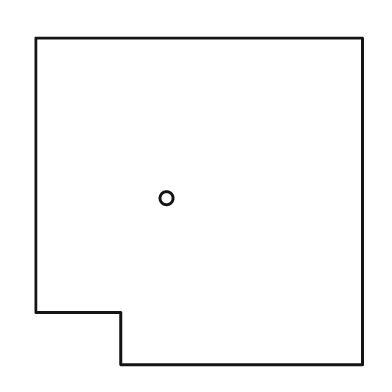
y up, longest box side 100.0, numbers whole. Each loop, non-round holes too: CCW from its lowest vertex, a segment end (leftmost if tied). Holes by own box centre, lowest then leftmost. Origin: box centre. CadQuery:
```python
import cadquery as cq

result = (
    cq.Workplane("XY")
    .moveTo(-24.0, -50.0)
    .lineTo(50.0, -50.0)
    .lineTo(50.0, 50.0)
    .lineTo(-50.0, 50.0)
    .lineTo(-50.0, -34.0)
    .lineTo(-24.0, -34.0)
    .close()
    .moveTo(-10.0, 1.0)
    .circle(2.0)
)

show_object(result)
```